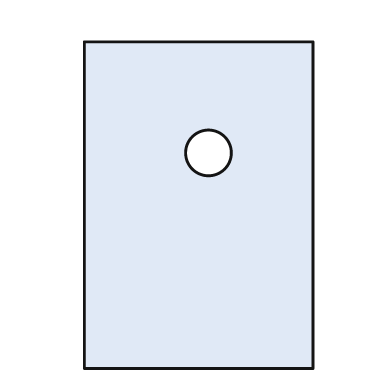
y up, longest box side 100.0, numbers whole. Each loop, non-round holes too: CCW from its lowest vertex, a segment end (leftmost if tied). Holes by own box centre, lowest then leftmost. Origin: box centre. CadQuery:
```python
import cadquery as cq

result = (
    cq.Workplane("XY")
    .moveTo(-35.0, -50.0)
    .lineTo(35.0, -50.0)
    .lineTo(35.0, 50.0)
    .lineTo(-35.0, 50.0)
    .close()
    .moveTo(3.0, 16.0)
    .circle(7.0)
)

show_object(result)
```